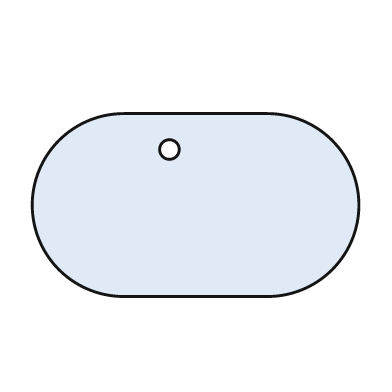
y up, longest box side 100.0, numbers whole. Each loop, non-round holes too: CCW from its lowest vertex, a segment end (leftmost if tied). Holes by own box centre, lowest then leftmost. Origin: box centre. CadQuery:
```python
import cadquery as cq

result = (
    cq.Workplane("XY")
    .moveTo(-22.0, -28.0)
    .lineTo(22.0, -28.0)
    .threePointArc((50.0, 0.0), (22.0, 28.0))
    .lineTo(-22.0, 28.0)
    .threePointArc((-50.0, 0.0), (-22.0, -28.0))
    .close()
    .moveTo(-8.0, 17.0)
    .circle(3.0)
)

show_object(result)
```